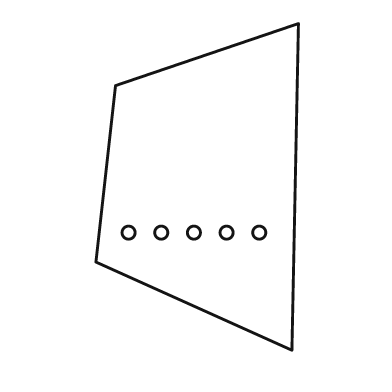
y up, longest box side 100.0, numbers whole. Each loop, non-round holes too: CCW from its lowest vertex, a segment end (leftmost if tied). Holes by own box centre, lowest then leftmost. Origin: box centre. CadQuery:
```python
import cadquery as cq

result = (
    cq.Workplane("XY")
    .moveTo(29.0, -50.0)
    .lineTo(31.0, 50.0)
    .lineTo(-25.0, 31.0)
    .lineTo(-31.0, -23.0)
    .close()
    .moveTo(-21.0, -14.0)
    .circle(2.0)
    .moveTo(-11.0, -14.0)
    .circle(2.0)
    .moveTo(-1.0, -14.0)
    .circle(2.0)
    .moveTo(9.0, -14.0)
    .circle(2.0)
    .moveTo(19.0, -14.0)
    .circle(2.0)
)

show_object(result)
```